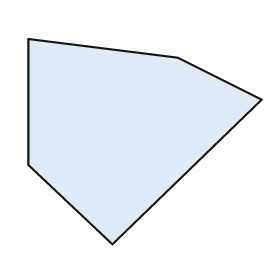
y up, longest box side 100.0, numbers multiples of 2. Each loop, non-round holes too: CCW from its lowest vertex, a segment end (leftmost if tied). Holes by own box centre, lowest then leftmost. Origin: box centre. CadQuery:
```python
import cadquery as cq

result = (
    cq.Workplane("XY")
    .moveTo(-14.0, -44.0)
    .lineTo(50.0, 18.0)
    .lineTo(14.0, 36.0)
    .lineTo(-50.0, 44.0)
    .lineTo(-50.0, -10.0)
    .close()
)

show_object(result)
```